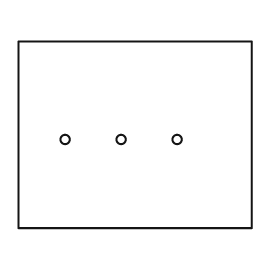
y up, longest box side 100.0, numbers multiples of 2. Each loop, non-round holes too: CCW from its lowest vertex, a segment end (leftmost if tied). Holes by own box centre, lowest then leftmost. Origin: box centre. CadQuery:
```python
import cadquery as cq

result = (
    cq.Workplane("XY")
    .moveTo(-50.0, -40.0)
    .lineTo(50.0, -40.0)
    .lineTo(50.0, 40.0)
    .lineTo(-50.0, 40.0)
    .close()
    .moveTo(-30.0, -2.0)
    .circle(2.0)
    .moveTo(-6.0, -2.0)
    .circle(2.0)
    .moveTo(18.0, -2.0)
    .circle(2.0)
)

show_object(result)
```